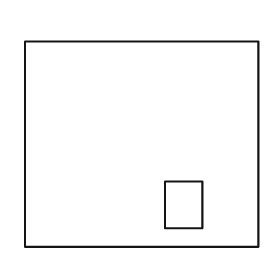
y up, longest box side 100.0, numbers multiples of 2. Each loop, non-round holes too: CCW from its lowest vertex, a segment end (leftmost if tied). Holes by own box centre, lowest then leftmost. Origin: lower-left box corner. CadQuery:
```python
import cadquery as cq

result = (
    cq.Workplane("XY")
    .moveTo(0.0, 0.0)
    .lineTo(100.0, 0.0)
    .lineTo(100.0, 88.0)
    .lineTo(0.0, 88.0)
    .close()
    .moveTo(60.0, 8.0)
    .lineTo(76.0, 8.0)
    .lineTo(76.0, 28.0)
    .lineTo(60.0, 28.0)
    .close()
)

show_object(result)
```